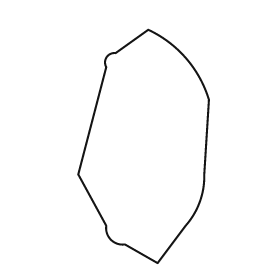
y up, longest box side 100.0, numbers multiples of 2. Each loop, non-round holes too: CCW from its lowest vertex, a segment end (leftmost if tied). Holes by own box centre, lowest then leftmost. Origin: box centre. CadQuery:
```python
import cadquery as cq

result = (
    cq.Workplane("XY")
    .moveTo(6.0, -50.0)
    .lineTo(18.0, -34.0)
    .threePointArc((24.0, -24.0), (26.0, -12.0))
    .lineTo(28.0, 20.0)
    .threePointArc((18.0, 38.0), (2.0, 50.0))
    .lineTo(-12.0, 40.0)
    .threePointArc((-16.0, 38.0), (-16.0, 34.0))
    .lineTo(-28.0, -12.0)
    .lineTo(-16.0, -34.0)
    .threePointArc((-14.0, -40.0), (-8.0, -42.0))
    .close()
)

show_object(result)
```